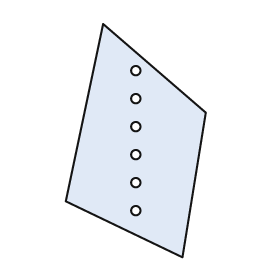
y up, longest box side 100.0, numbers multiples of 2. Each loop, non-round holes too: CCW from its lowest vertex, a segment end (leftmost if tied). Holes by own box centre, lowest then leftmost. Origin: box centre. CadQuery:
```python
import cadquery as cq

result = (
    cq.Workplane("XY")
    .moveTo(20.0, -50.0)
    .lineTo(30.0, 12.0)
    .lineTo(-14.0, 50.0)
    .lineTo(-30.0, -26.0)
    .close()
    .moveTo(0.0, -30.0)
    .circle(2.0)
    .moveTo(0.0, -18.0)
    .circle(2.0)
    .moveTo(0.0, -6.0)
    .circle(2.0)
    .moveTo(0.0, 6.0)
    .circle(2.0)
    .moveTo(0.0, 18.0)
    .circle(2.0)
    .moveTo(0.0, 30.0)
    .circle(2.0)
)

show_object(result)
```